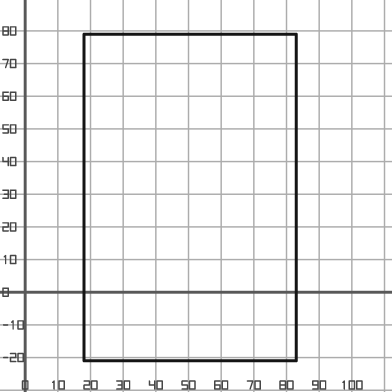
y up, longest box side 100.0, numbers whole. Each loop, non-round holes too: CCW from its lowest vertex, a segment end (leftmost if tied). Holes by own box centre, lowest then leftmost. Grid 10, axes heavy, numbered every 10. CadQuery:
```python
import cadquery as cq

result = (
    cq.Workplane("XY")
    .moveTo(18.0, -21.0)
    .lineTo(83.0, -21.0)
    .lineTo(83.0, 79.0)
    .lineTo(18.0, 79.0)
    .close()
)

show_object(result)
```